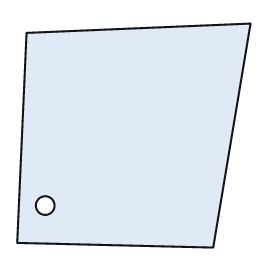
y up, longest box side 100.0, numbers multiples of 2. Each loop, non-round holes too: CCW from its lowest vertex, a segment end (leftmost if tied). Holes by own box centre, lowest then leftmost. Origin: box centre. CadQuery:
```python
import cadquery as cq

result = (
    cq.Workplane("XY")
    .moveTo(34.0, -48.0)
    .lineTo(50.0, 48.0)
    .lineTo(-46.0, 44.0)
    .lineTo(-50.0, -46.0)
    .close()
    .moveTo(-38.0, -30.0)
    .circle(4.0)
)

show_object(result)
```